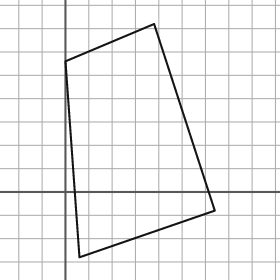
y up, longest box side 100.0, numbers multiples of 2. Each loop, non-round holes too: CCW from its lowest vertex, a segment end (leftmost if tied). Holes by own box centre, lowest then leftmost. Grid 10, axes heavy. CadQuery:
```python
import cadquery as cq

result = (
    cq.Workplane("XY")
    .moveTo(6.0, -28.0)
    .lineTo(64.0, -8.0)
    .lineTo(38.0, 72.0)
    .lineTo(0.0, 56.0)
    .close()
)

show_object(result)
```